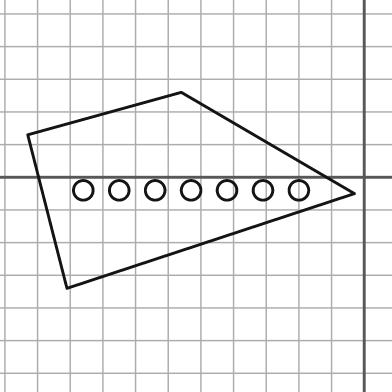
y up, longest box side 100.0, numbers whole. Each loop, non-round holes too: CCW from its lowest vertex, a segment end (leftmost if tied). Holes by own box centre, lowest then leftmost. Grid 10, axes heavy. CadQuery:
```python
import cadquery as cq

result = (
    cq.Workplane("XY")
    .moveTo(-91.0, -34.0)
    .lineTo(-3.0, -5.0)
    .lineTo(-56.0, 26.0)
    .lineTo(-103.0, 13.0)
    .close()
    .moveTo(-86.0, -4.0)
    .circle(3.0)
    .moveTo(-75.0, -4.0)
    .circle(3.0)
    .moveTo(-64.0, -4.0)
    .circle(3.0)
    .moveTo(-53.0, -4.0)
    .circle(3.0)
    .moveTo(-42.0, -4.0)
    .circle(3.0)
    .moveTo(-31.0, -4.0)
    .circle(3.0)
    .moveTo(-20.0, -4.0)
    .circle(3.0)
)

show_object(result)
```